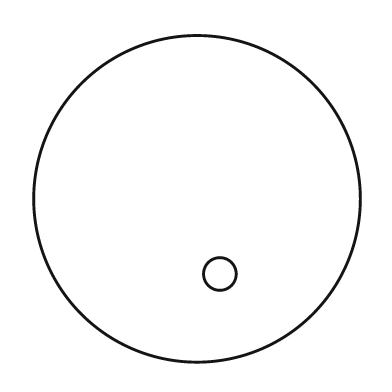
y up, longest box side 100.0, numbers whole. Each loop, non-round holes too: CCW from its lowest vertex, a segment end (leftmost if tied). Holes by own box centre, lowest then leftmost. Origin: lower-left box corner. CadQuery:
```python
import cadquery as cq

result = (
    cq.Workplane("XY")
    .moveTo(50.0, 50.0)
    .circle(50.0)
    .moveTo(57.0, 27.0)
    .circle(5.0)
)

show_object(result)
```